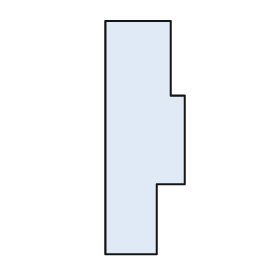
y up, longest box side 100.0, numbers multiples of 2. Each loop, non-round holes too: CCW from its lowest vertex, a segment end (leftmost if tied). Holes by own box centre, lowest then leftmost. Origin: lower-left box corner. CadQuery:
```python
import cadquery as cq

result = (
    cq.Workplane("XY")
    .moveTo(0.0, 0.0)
    .lineTo(22.0, 0.0)
    .lineTo(22.0, 30.0)
    .lineTo(34.0, 30.0)
    .lineTo(34.0, 68.0)
    .lineTo(28.0, 68.0)
    .lineTo(28.0, 100.0)
    .lineTo(0.0, 100.0)
    .close()
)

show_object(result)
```